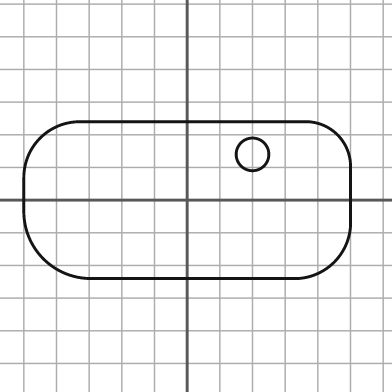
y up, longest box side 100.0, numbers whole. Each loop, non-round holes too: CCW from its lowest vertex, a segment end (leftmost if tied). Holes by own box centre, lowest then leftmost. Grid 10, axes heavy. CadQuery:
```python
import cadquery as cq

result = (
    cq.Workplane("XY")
    .moveTo(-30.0, -24.0)
    .lineTo(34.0, -24.0)
    .threePointArc((45.0, -19.0), (50.0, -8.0))
    .lineTo(50.0, 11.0)
    .threePointArc((46.0, 20.0), (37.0, 24.0))
    .lineTo(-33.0, 24.0)
    .threePointArc((-45.0, 19.0), (-50.0, 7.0))
    .lineTo(-50.0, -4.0)
    .threePointArc((-44.0, -18.0), (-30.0, -24.0))
    .close()
    .moveTo(20.0, 14.0)
    .circle(5.0)
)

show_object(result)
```